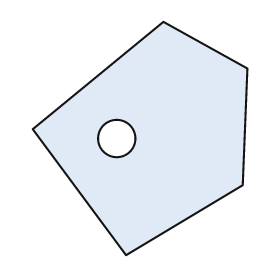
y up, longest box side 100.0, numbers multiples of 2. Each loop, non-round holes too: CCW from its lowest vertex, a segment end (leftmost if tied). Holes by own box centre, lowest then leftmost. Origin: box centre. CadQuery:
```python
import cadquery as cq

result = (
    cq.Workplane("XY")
    .moveTo(-6.0, -50.0)
    .lineTo(44.0, -20.0)
    .lineTo(46.0, 30.0)
    .lineTo(10.0, 50.0)
    .lineTo(-46.0, 4.0)
    .close()
    .moveTo(-10.0, 0.0)
    .circle(8.0)
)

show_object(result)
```